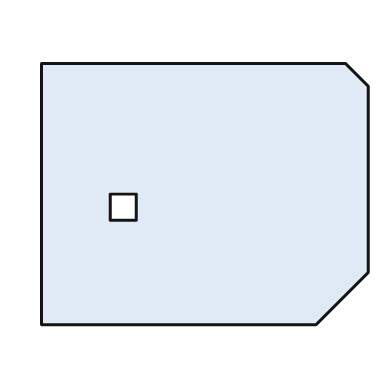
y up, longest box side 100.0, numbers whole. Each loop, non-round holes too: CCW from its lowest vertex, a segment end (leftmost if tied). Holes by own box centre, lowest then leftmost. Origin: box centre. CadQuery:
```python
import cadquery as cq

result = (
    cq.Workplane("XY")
    .moveTo(-50.0, -40.0)
    .lineTo(34.0, -40.0)
    .lineTo(50.0, -24.0)
    .lineTo(50.0, 33.0)
    .lineTo(43.0, 40.0)
    .lineTo(-50.0, 40.0)
    .close()
    .moveTo(-29.0, -8.0)
    .lineTo(-21.0, -8.0)
    .lineTo(-21.0, 0.0)
    .lineTo(-29.0, 0.0)
    .close()
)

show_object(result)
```